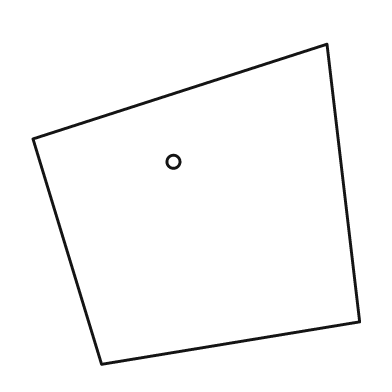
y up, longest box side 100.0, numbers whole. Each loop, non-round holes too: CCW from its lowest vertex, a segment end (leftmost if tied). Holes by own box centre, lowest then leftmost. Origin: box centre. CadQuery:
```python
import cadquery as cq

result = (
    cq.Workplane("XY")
    .moveTo(-29.0, -49.0)
    .lineTo(50.0, -36.0)
    .lineTo(40.0, 49.0)
    .lineTo(-50.0, 20.0)
    .close()
    .moveTo(-7.0, 13.0)
    .circle(2.0)
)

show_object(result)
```